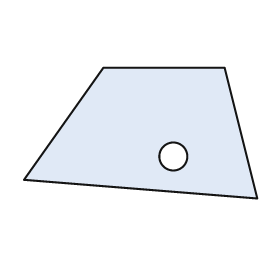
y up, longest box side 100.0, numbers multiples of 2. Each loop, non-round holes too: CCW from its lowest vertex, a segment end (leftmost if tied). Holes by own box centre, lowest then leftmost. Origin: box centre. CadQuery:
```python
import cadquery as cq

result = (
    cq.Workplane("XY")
    .moveTo(50.0, -28.0)
    .lineTo(36.0, 28.0)
    .lineTo(-16.0, 28.0)
    .lineTo(-50.0, -20.0)
    .close()
    .moveTo(14.0, -10.0)
    .circle(6.0)
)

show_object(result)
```